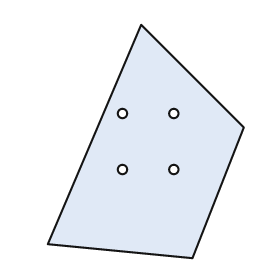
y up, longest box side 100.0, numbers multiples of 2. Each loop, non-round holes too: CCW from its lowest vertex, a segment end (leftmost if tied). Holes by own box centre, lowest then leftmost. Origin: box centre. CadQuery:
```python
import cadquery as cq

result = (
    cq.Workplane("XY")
    .moveTo(20.0, -50.0)
    .lineTo(42.0, 6.0)
    .lineTo(-2.0, 50.0)
    .lineTo(-42.0, -44.0)
    .close()
    .moveTo(-10.0, -12.0)
    .circle(2.0)
    .moveTo(12.0, -12.0)
    .circle(2.0)
    .moveTo(-10.0, 12.0)
    .circle(2.0)
    .moveTo(12.0, 12.0)
    .circle(2.0)
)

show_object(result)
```